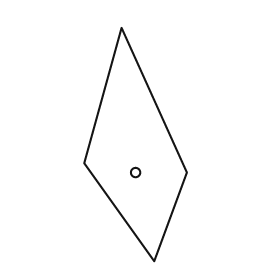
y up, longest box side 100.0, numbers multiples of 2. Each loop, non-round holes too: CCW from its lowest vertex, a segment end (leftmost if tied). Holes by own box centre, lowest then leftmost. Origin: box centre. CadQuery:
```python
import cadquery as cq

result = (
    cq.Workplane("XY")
    .moveTo(8.0, -50.0)
    .lineTo(22.0, -12.0)
    .lineTo(-6.0, 50.0)
    .lineTo(-22.0, -8.0)
    .close()
    .moveTo(0.0, -12.0)
    .circle(2.0)
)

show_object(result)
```